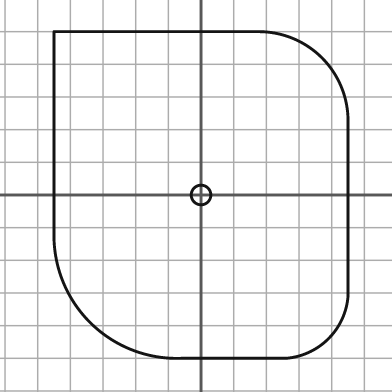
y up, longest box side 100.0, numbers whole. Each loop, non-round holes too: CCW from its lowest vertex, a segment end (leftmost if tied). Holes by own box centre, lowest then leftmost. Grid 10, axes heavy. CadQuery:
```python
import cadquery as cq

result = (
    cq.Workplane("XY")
    .moveTo(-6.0, -50.0)
    .lineTo(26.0, -50.0)
    .threePointArc((39.0, -44.0), (45.0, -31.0))
    .lineTo(45.0, 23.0)
    .threePointArc((37.0, 42.0), (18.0, 50.0))
    .lineTo(-45.0, 50.0)
    .lineTo(-45.0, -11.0)
    .threePointArc((-34.0, -39.0), (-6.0, -50.0))
    .close()
    .moveTo(0.0, 0.0)
    .circle(3.0)
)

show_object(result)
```